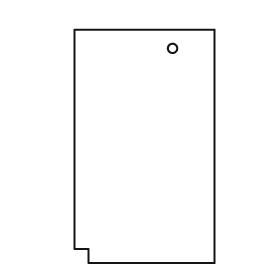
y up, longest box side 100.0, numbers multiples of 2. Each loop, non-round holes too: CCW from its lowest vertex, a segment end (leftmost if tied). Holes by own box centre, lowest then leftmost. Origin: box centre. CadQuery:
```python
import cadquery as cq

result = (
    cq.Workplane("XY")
    .moveTo(-24.0, -50.0)
    .lineTo(30.0, -50.0)
    .lineTo(30.0, 50.0)
    .lineTo(-30.0, 50.0)
    .lineTo(-30.0, -44.0)
    .lineTo(-24.0, -44.0)
    .close()
    .moveTo(12.0, 42.0)
    .circle(2.0)
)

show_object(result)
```